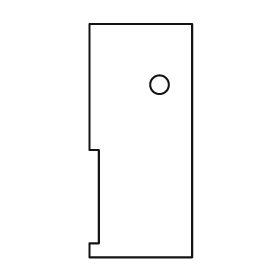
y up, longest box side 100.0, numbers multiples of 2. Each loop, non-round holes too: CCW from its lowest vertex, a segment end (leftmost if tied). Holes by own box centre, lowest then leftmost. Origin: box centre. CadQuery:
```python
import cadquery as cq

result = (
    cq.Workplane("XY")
    .moveTo(-22.0, -50.0)
    .lineTo(22.0, -50.0)
    .lineTo(22.0, 50.0)
    .lineTo(-22.0, 50.0)
    .lineTo(-22.0, -4.0)
    .lineTo(-18.0, -4.0)
    .lineTo(-18.0, -44.0)
    .lineTo(-22.0, -44.0)
    .close()
    .moveTo(8.0, 24.0)
    .circle(4.0)
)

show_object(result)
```